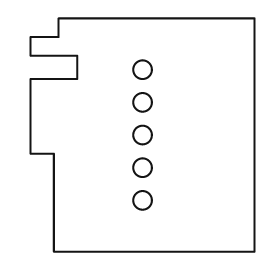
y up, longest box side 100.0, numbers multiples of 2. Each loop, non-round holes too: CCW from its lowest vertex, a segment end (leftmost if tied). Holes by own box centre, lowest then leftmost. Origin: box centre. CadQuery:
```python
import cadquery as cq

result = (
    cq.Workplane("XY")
    .moveTo(-38.0, -50.0)
    .lineTo(48.0, -50.0)
    .lineTo(48.0, 50.0)
    .lineTo(-36.0, 50.0)
    .lineTo(-36.0, 42.0)
    .lineTo(-48.0, 42.0)
    .lineTo(-48.0, 34.0)
    .lineTo(-28.0, 34.0)
    .lineTo(-28.0, 24.0)
    .lineTo(-48.0, 24.0)
    .lineTo(-48.0, -8.0)
    .lineTo(-38.0, -8.0)
    .close()
    .moveTo(0.0, -28.0)
    .circle(4.0)
    .moveTo(0.0, -14.0)
    .circle(4.0)
    .moveTo(0.0, 0.0)
    .circle(4.0)
    .moveTo(0.0, 14.0)
    .circle(4.0)
    .moveTo(0.0, 28.0)
    .circle(4.0)
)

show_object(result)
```